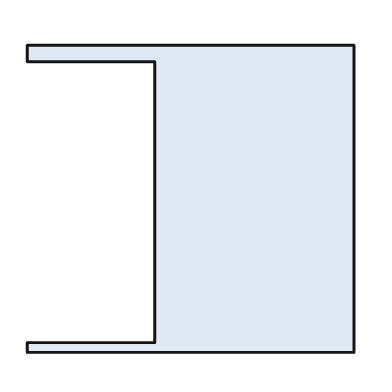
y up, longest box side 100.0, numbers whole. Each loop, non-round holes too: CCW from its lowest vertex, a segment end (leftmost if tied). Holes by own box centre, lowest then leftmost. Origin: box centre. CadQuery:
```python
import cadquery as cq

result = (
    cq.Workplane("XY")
    .moveTo(-50.0, -47.0)
    .lineTo(50.0, -47.0)
    .lineTo(50.0, 47.0)
    .lineTo(-50.0, 47.0)
    .lineTo(-50.0, 42.0)
    .lineTo(-11.0, 42.0)
    .lineTo(-11.0, -44.0)
    .lineTo(-50.0, -44.0)
    .close()
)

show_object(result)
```